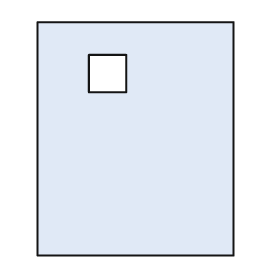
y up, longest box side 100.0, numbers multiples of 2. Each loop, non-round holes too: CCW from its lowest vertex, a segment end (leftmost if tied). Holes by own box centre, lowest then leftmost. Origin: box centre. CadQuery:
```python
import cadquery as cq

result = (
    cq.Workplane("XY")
    .moveTo(-42.0, -50.0)
    .lineTo(42.0, -50.0)
    .lineTo(42.0, 50.0)
    .lineTo(-42.0, 50.0)
    .close()
    .moveTo(-20.0, 20.0)
    .lineTo(-4.0, 20.0)
    .lineTo(-4.0, 36.0)
    .lineTo(-20.0, 36.0)
    .close()
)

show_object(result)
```